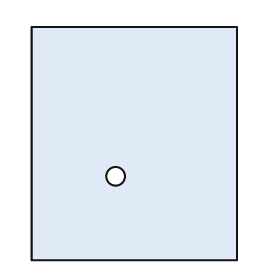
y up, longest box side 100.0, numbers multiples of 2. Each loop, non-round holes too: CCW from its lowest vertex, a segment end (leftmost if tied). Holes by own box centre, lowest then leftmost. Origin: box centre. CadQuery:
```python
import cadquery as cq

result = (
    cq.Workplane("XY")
    .moveTo(-44.0, -50.0)
    .lineTo(44.0, -50.0)
    .lineTo(44.0, 50.0)
    .lineTo(-44.0, 50.0)
    .close()
    .moveTo(-8.0, -14.0)
    .circle(4.0)
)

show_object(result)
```